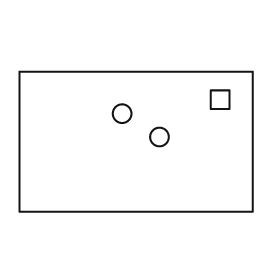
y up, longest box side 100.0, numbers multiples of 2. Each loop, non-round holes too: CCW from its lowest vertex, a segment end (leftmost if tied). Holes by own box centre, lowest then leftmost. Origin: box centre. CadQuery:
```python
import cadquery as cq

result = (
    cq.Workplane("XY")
    .moveTo(-50.0, -30.0)
    .lineTo(50.0, -30.0)
    .lineTo(50.0, 30.0)
    .lineTo(-50.0, 30.0)
    .close()
    .moveTo(10.0, 2.0)
    .circle(4.0)
    .moveTo(-6.0, 12.0)
    .circle(4.0)
    .moveTo(32.0, 14.0)
    .lineTo(40.0, 14.0)
    .lineTo(40.0, 22.0)
    .lineTo(32.0, 22.0)
    .close()
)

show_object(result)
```